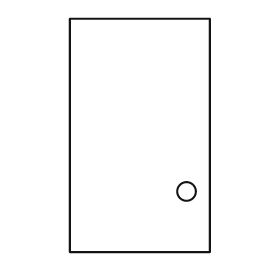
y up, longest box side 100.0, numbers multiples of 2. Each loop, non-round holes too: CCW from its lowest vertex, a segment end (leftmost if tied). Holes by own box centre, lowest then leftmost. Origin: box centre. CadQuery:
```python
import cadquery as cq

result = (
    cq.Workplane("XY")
    .moveTo(-30.0, -50.0)
    .lineTo(30.0, -50.0)
    .lineTo(30.0, 50.0)
    .lineTo(-30.0, 50.0)
    .close()
    .moveTo(20.0, -24.0)
    .circle(4.0)
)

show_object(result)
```